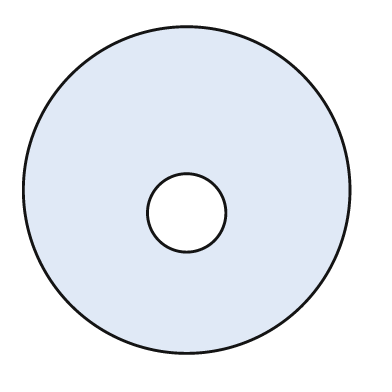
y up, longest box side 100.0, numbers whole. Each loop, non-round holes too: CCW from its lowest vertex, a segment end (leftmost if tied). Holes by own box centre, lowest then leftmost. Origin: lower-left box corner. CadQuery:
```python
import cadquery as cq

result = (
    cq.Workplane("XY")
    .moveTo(50.0, 50.0)
    .circle(50.0)
    .moveTo(50.0, 43.0)
    .circle(12.0)
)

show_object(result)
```